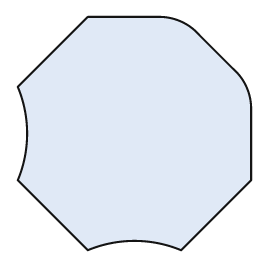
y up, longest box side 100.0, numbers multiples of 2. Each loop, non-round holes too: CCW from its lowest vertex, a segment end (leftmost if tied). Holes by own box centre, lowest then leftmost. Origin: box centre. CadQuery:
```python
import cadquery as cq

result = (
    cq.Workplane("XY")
    .moveTo(-20.0, -50.0)
    .threePointArc((0.0, -46.0), (20.0, -50.0))
    .lineTo(50.0, -20.0)
    .lineTo(50.0, 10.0)
    .threePointArc((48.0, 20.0), (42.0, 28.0))
    .lineTo(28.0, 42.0)
    .threePointArc((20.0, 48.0), (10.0, 50.0))
    .lineTo(-20.0, 50.0)
    .lineTo(-50.0, 20.0)
    .threePointArc((-46.0, 0.0), (-50.0, -20.0))
    .close()
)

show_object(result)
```